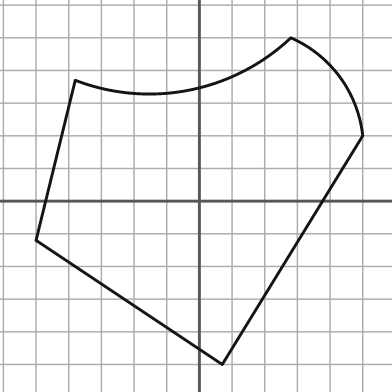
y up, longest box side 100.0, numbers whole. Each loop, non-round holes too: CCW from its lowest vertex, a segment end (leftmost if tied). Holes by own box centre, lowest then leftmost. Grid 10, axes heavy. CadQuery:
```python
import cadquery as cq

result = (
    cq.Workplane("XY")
    .moveTo(7.0, -50.0)
    .lineTo(50.0, 20.0)
    .threePointArc((43.0, 38.0), (28.0, 50.0))
    .threePointArc((-3.0, 34.0), (-38.0, 37.0))
    .lineTo(-50.0, -12.0)
    .close()
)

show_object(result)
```